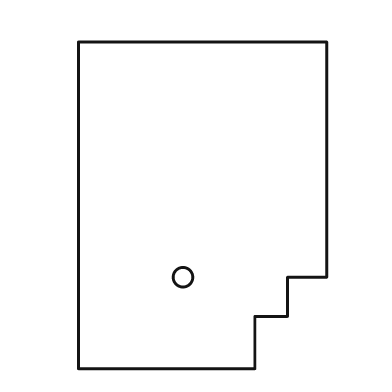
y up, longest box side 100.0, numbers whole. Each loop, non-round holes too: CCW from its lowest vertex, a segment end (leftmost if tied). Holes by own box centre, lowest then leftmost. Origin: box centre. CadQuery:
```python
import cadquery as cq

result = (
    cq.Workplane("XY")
    .moveTo(-38.0, -50.0)
    .lineTo(16.0, -50.0)
    .lineTo(16.0, -34.0)
    .lineTo(26.0, -34.0)
    .lineTo(26.0, -22.0)
    .lineTo(38.0, -22.0)
    .lineTo(38.0, 50.0)
    .lineTo(-38.0, 50.0)
    .close()
    .moveTo(-6.0, -22.0)
    .circle(3.0)
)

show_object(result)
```